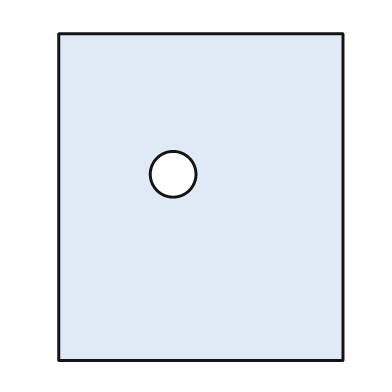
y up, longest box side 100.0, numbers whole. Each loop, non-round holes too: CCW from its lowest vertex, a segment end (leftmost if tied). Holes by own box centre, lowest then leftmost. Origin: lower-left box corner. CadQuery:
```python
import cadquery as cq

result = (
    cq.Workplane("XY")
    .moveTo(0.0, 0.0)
    .lineTo(87.0, 0.0)
    .lineTo(87.0, 100.0)
    .lineTo(0.0, 100.0)
    .close()
    .moveTo(35.0, 57.0)
    .circle(7.0)
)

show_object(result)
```